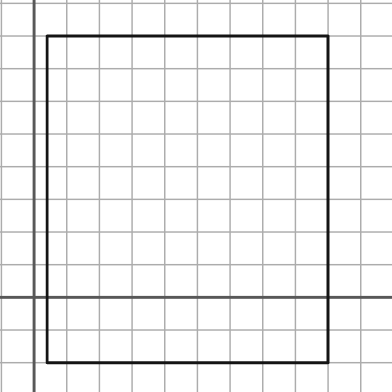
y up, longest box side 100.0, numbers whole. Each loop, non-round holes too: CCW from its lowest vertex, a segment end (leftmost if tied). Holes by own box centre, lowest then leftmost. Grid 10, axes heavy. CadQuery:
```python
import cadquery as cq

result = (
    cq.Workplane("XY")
    .moveTo(4.0, -20.0)
    .lineTo(90.0, -20.0)
    .lineTo(90.0, 80.0)
    .lineTo(4.0, 80.0)
    .close()
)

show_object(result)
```